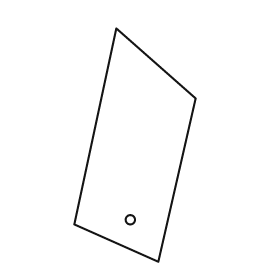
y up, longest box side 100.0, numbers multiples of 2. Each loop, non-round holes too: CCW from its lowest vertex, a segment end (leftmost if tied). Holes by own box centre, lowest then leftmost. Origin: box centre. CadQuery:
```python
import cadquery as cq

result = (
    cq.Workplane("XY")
    .moveTo(10.0, -50.0)
    .lineTo(26.0, 20.0)
    .lineTo(-8.0, 50.0)
    .lineTo(-26.0, -34.0)
    .close()
    .moveTo(-2.0, -32.0)
    .circle(2.0)
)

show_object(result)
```